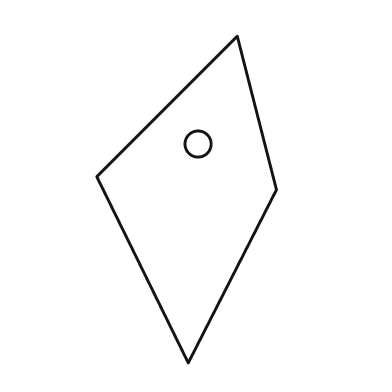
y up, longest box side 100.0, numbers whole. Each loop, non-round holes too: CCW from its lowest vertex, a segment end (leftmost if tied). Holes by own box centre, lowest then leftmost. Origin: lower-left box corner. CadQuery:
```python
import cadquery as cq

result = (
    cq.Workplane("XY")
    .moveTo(28.0, 0.0)
    .lineTo(55.0, 53.0)
    .lineTo(43.0, 100.0)
    .lineTo(0.0, 57.0)
    .close()
    .moveTo(31.0, 67.0)
    .circle(4.0)
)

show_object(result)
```